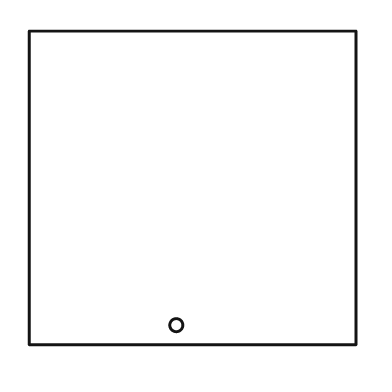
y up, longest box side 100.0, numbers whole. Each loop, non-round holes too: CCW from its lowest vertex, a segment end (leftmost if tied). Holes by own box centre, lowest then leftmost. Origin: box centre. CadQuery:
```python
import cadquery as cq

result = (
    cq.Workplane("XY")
    .moveTo(-50.0, -48.0)
    .lineTo(50.0, -48.0)
    .lineTo(50.0, 48.0)
    .lineTo(-50.0, 48.0)
    .close()
    .moveTo(-5.0, -42.0)
    .circle(2.0)
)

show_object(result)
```